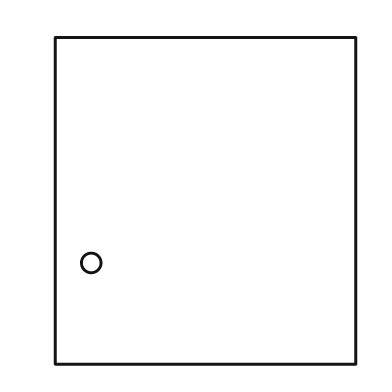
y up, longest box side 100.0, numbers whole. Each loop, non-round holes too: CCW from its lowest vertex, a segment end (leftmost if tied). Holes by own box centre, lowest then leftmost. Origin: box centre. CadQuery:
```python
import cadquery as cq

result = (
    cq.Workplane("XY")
    .moveTo(-46.0, -50.0)
    .lineTo(46.0, -50.0)
    .lineTo(46.0, 50.0)
    .lineTo(-46.0, 50.0)
    .close()
    .moveTo(-35.0, -19.0)
    .circle(3.0)
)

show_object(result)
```